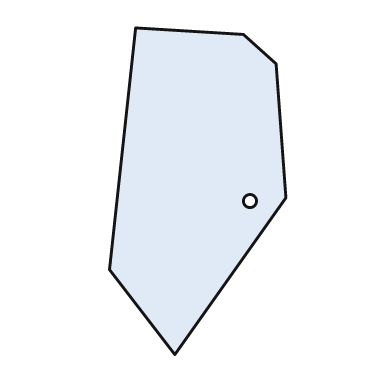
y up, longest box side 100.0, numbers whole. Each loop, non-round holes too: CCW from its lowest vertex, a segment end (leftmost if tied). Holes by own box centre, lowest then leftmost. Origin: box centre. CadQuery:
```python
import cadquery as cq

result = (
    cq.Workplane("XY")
    .moveTo(-7.0, -50.0)
    .lineTo(27.0, -2.0)
    .lineTo(24.0, 39.0)
    .lineTo(14.0, 48.0)
    .lineTo(-19.0, 50.0)
    .lineTo(-27.0, -24.0)
    .close()
    .moveTo(16.0, -3.0)
    .circle(2.0)
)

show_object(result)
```